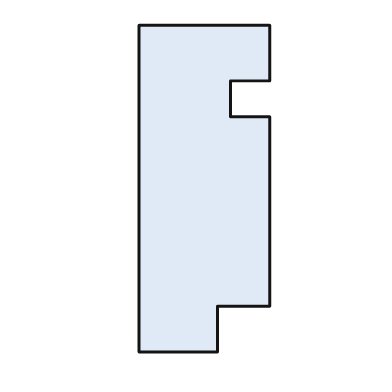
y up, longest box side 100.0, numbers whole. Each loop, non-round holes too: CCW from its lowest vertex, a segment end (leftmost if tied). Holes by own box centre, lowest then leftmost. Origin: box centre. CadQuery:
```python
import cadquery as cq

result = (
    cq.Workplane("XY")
    .moveTo(-20.0, -50.0)
    .lineTo(4.0, -50.0)
    .lineTo(4.0, -36.0)
    .lineTo(20.0, -36.0)
    .lineTo(20.0, 22.0)
    .lineTo(8.0, 22.0)
    .lineTo(8.0, 33.0)
    .lineTo(20.0, 33.0)
    .lineTo(20.0, 50.0)
    .lineTo(-20.0, 50.0)
    .close()
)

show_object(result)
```